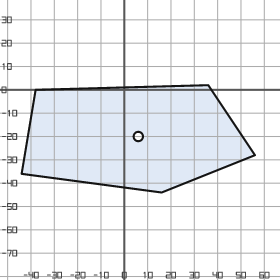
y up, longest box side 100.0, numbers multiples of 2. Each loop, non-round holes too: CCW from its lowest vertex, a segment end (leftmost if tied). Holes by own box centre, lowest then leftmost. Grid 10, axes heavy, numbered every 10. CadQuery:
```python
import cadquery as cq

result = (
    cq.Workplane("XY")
    .moveTo(16.0, -44.0)
    .lineTo(56.0, -28.0)
    .lineTo(36.0, 2.0)
    .lineTo(-38.0, 0.0)
    .lineTo(-44.0, -36.0)
    .close()
    .moveTo(6.0, -20.0)
    .circle(2.0)
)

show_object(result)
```